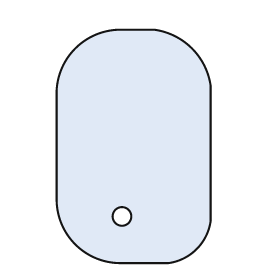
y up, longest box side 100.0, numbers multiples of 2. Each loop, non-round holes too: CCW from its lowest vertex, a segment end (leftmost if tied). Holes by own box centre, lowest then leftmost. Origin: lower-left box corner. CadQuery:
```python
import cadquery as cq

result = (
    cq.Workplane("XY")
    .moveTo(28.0, 0.0)
    .lineTo(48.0, 0.0)
    .threePointArc((60.0, 6.0), (66.0, 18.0))
    .lineTo(66.0, 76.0)
    .threePointArc((58.0, 92.0), (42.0, 100.0))
    .lineTo(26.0, 100.0)
    .threePointArc((8.0, 92.0), (0.0, 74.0))
    .lineTo(0.0, 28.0)
    .threePointArc((8.0, 8.0), (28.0, 0.0))
    .close()
    .moveTo(28.0, 20.0)
    .circle(4.0)
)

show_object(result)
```